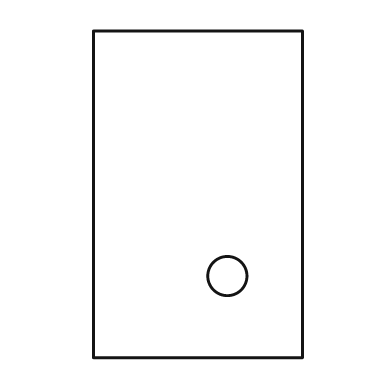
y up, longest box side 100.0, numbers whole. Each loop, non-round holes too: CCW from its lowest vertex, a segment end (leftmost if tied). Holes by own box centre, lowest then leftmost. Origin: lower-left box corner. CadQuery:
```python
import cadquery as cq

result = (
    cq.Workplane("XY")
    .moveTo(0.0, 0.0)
    .lineTo(64.0, 0.0)
    .lineTo(64.0, 100.0)
    .lineTo(0.0, 100.0)
    .close()
    .moveTo(41.0, 25.0)
    .circle(6.0)
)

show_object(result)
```